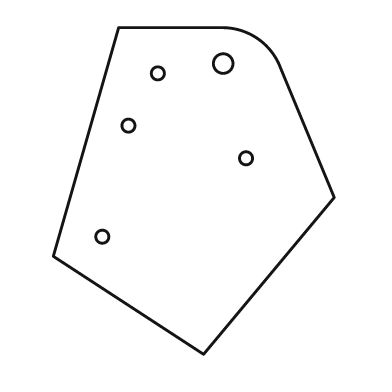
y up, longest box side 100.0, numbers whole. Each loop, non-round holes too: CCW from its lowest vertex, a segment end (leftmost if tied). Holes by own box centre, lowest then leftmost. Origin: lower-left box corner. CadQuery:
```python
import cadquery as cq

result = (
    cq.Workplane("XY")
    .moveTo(46.0, 0.0)
    .lineTo(86.0, 48.0)
    .lineTo(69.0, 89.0)
    .threePointArc((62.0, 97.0), (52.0, 100.0))
    .lineTo(20.0, 100.0)
    .lineTo(0.0, 30.0)
    .close()
    .moveTo(15.0, 36.0)
    .circle(2.0)
    .moveTo(59.0, 60.0)
    .circle(2.0)
    .moveTo(23.0, 70.0)
    .circle(2.0)
    .moveTo(32.0, 86.0)
    .circle(2.0)
    .moveTo(52.0, 89.0)
    .circle(3.0)
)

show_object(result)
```